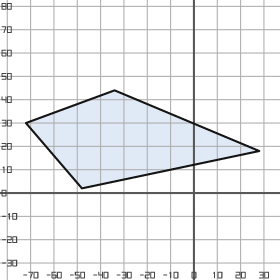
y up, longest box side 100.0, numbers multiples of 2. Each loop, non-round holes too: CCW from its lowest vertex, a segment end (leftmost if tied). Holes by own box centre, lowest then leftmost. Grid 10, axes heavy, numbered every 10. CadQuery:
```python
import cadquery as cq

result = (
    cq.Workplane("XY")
    .moveTo(-48.0, 2.0)
    .lineTo(28.0, 18.0)
    .lineTo(-34.0, 44.0)
    .lineTo(-72.0, 30.0)
    .close()
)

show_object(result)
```